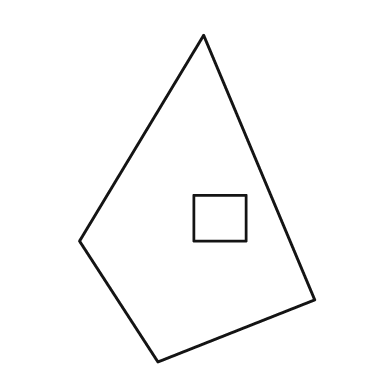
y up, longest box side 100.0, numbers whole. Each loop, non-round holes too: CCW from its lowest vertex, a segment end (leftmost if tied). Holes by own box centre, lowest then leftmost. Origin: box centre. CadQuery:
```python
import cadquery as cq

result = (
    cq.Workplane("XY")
    .moveTo(-12.0, -50.0)
    .lineTo(36.0, -31.0)
    .lineTo(2.0, 50.0)
    .lineTo(-36.0, -13.0)
    .close()
    .moveTo(-1.0, -13.0)
    .lineTo(15.0, -13.0)
    .lineTo(15.0, 1.0)
    .lineTo(-1.0, 1.0)
    .close()
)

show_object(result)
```